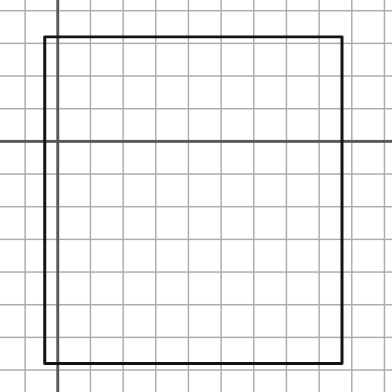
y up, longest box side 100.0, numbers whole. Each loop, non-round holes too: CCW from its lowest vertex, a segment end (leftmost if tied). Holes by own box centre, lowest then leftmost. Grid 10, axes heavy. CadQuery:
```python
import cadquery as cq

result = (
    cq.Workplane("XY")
    .moveTo(-4.0, -68.0)
    .lineTo(87.0, -68.0)
    .lineTo(87.0, 32.0)
    .lineTo(-4.0, 32.0)
    .close()
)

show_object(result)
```